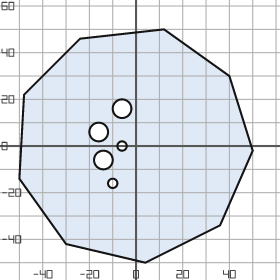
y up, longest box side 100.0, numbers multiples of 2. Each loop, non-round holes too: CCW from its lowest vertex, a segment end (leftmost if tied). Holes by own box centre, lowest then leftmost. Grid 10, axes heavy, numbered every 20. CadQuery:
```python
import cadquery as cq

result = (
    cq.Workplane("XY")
    .moveTo(4.0, -50.0)
    .lineTo(36.0, -34.0)
    .lineTo(50.0, -2.0)
    .lineTo(40.0, 30.0)
    .lineTo(12.0, 50.0)
    .lineTo(-24.0, 46.0)
    .lineTo(-48.0, 22.0)
    .lineTo(-50.0, -14.0)
    .lineTo(-30.0, -42.0)
    .close()
    .moveTo(-10.0, -16.0)
    .circle(2.0)
    .moveTo(-14.0, -6.0)
    .circle(4.0)
    .moveTo(-6.0, 0.0)
    .circle(2.0)
    .moveTo(-16.0, 6.0)
    .circle(4.0)
    .moveTo(-6.0, 16.0)
    .circle(4.0)
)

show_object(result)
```